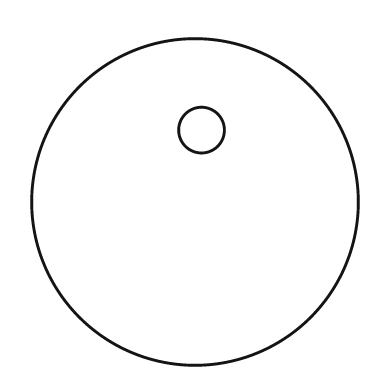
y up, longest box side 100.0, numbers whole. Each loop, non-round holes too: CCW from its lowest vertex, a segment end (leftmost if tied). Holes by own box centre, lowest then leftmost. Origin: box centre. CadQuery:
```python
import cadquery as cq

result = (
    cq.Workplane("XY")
    .moveTo(0.0, 0.0)
    .circle(50.0)
    .moveTo(2.0, 22.0)
    .circle(7.0)
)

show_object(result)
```